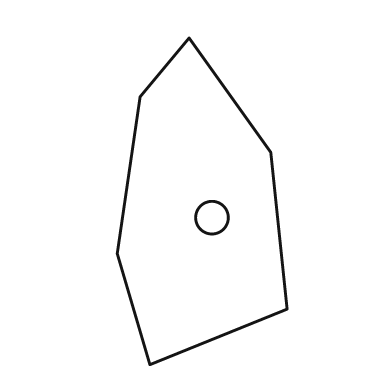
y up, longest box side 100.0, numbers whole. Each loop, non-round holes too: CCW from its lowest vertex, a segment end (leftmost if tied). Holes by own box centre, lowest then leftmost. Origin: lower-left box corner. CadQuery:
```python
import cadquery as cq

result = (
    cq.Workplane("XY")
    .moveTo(10.0, 0.0)
    .lineTo(52.0, 17.0)
    .lineTo(47.0, 65.0)
    .lineTo(22.0, 100.0)
    .lineTo(7.0, 82.0)
    .lineTo(0.0, 34.0)
    .close()
    .moveTo(29.0, 45.0)
    .circle(5.0)
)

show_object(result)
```